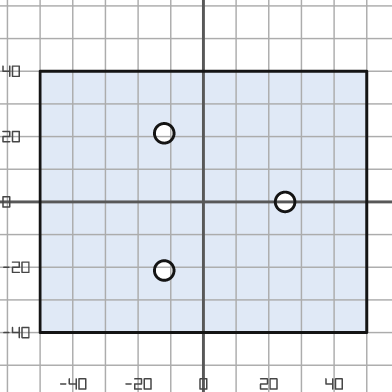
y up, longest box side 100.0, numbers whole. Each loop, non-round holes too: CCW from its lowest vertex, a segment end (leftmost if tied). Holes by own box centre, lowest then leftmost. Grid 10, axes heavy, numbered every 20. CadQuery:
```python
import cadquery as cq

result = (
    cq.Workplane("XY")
    .moveTo(-50.0, -40.0)
    .lineTo(50.0, -40.0)
    .lineTo(50.0, 40.0)
    .lineTo(-50.0, 40.0)
    .close()
    .moveTo(-12.0, -21.0)
    .circle(3.0)
    .moveTo(25.0, 0.0)
    .circle(3.0)
    .moveTo(-12.0, 21.0)
    .circle(3.0)
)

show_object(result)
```